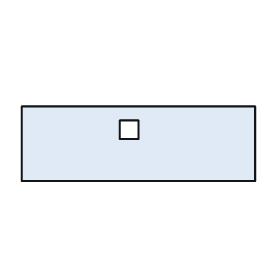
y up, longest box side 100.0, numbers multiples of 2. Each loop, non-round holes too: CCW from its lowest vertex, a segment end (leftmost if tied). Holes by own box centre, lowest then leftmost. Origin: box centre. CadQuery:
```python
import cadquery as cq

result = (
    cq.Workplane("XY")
    .moveTo(-50.0, -16.0)
    .lineTo(50.0, -16.0)
    .lineTo(50.0, 16.0)
    .lineTo(-50.0, 16.0)
    .close()
    .moveTo(-8.0, 2.0)
    .lineTo(0.0, 2.0)
    .lineTo(0.0, 10.0)
    .lineTo(-8.0, 10.0)
    .close()
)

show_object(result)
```